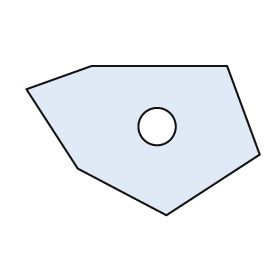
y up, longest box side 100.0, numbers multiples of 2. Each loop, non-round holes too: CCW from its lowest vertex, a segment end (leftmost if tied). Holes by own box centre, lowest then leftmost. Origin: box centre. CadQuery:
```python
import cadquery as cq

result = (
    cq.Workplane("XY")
    .moveTo(10.0, -32.0)
    .lineTo(50.0, -6.0)
    .lineTo(36.0, 32.0)
    .lineTo(-22.0, 32.0)
    .lineTo(-50.0, 22.0)
    .lineTo(-28.0, -12.0)
    .close()
    .moveTo(6.0, 6.0)
    .circle(8.0)
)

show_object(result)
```